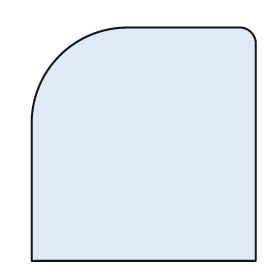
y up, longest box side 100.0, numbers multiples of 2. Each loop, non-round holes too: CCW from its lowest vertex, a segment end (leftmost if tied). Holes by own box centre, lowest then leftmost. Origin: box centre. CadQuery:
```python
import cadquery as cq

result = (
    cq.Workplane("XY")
    .moveTo(-48.0, -50.0)
    .lineTo(48.0, -50.0)
    .lineTo(48.0, 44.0)
    .threePointArc((46.0, 48.0), (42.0, 50.0))
    .lineTo(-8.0, 50.0)
    .threePointArc((-36.0, 38.0), (-48.0, 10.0))
    .close()
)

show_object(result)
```